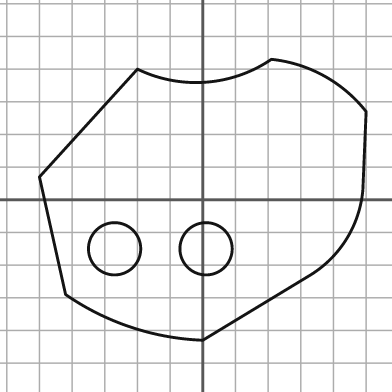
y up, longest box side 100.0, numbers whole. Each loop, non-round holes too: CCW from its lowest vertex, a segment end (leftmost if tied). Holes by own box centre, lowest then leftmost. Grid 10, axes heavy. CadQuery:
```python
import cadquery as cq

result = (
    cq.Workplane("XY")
    .moveTo(0.0, -43.0)
    .lineTo(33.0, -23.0)
    .threePointArc((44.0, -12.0), (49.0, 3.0))
    .lineTo(50.0, 27.0)
    .threePointArc((37.0, 38.0), (21.0, 43.0))
    .threePointArc((1.0, 36.0), (-20.0, 40.0))
    .lineTo(-50.0, 7.0)
    .lineTo(-42.0, -29.0)
    .threePointArc((-22.0, -39.0), (0.0, -43.0))
    .close()
    .moveTo(-27.0, -15.0)
    .circle(8.0)
    .moveTo(1.0, -15.0)
    .circle(8.0)
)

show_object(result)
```